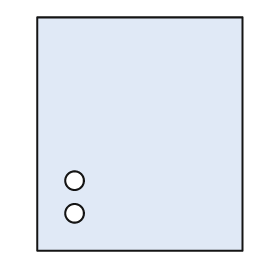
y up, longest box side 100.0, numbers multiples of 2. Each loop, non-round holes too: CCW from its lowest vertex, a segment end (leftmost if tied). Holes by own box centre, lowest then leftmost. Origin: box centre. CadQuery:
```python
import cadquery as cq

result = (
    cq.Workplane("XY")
    .moveTo(-44.0, -50.0)
    .lineTo(44.0, -50.0)
    .lineTo(44.0, 50.0)
    .lineTo(-44.0, 50.0)
    .close()
    .moveTo(-28.0, -34.0)
    .circle(4.0)
    .moveTo(-28.0, -20.0)
    .circle(4.0)
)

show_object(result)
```